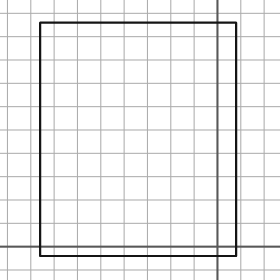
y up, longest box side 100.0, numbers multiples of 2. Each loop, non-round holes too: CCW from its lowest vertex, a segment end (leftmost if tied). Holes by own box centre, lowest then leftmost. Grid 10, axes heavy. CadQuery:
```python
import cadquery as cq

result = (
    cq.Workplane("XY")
    .moveTo(-76.0, -4.0)
    .lineTo(8.0, -4.0)
    .lineTo(8.0, 96.0)
    .lineTo(-76.0, 96.0)
    .close()
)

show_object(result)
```